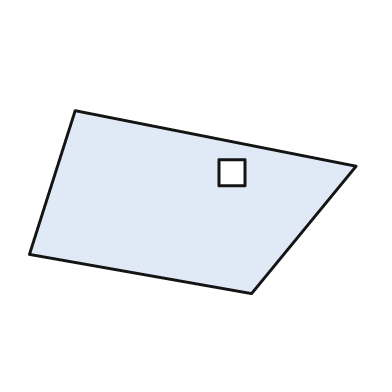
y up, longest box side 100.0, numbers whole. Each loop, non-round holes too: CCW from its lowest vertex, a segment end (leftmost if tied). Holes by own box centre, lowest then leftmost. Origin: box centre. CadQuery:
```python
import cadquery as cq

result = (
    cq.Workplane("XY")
    .moveTo(18.0, -28.0)
    .lineTo(50.0, 11.0)
    .lineTo(-36.0, 28.0)
    .lineTo(-50.0, -16.0)
    .close()
    .moveTo(8.0, 5.0)
    .lineTo(16.0, 5.0)
    .lineTo(16.0, 13.0)
    .lineTo(8.0, 13.0)
    .close()
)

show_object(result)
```